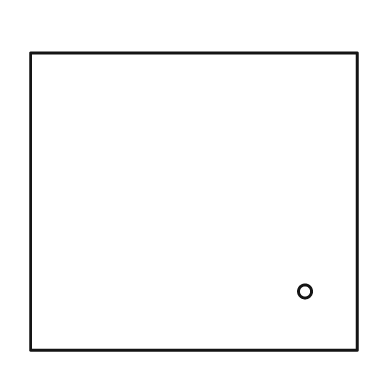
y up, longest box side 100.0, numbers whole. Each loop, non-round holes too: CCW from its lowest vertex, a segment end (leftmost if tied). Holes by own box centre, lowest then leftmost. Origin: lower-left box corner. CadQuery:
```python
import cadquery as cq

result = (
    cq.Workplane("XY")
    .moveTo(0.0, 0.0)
    .lineTo(100.0, 0.0)
    .lineTo(100.0, 91.0)
    .lineTo(0.0, 91.0)
    .close()
    .moveTo(84.0, 18.0)
    .circle(2.0)
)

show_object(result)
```